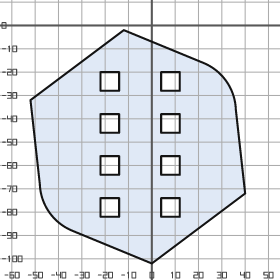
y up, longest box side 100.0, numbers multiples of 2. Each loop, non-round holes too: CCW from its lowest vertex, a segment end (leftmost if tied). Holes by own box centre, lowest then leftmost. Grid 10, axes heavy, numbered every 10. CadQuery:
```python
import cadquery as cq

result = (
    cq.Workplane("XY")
    .moveTo(0.0, -102.0)
    .lineTo(40.0, -72.0)
    .lineTo(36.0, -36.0)
    .threePointArc((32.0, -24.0), (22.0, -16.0))
    .lineTo(-12.0, -2.0)
    .lineTo(-52.0, -32.0)
    .lineTo(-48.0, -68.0)
    .threePointArc((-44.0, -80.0), (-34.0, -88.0))
    .close()
    .moveTo(-22.0, -82.0)
    .lineTo(-14.0, -82.0)
    .lineTo(-14.0, -74.0)
    .lineTo(-22.0, -74.0)
    .close()
    .moveTo(4.0, -82.0)
    .lineTo(12.0, -82.0)
    .lineTo(12.0, -74.0)
    .lineTo(4.0, -74.0)
    .close()
    .moveTo(-22.0, -64.0)
    .lineTo(-14.0, -64.0)
    .lineTo(-14.0, -56.0)
    .lineTo(-22.0, -56.0)
    .close()
    .moveTo(4.0, -64.0)
    .lineTo(12.0, -64.0)
    .lineTo(12.0, -56.0)
    .lineTo(4.0, -56.0)
    .close()
    .moveTo(-22.0, -46.0)
    .lineTo(-14.0, -46.0)
    .lineTo(-14.0, -38.0)
    .lineTo(-22.0, -38.0)
    .close()
    .moveTo(4.0, -46.0)
    .lineTo(12.0, -46.0)
    .lineTo(12.0, -38.0)
    .lineTo(4.0, -38.0)
    .close()
    .moveTo(-22.0, -28.0)
    .lineTo(-14.0, -28.0)
    .lineTo(-14.0, -20.0)
    .lineTo(-22.0, -20.0)
    .close()
    .moveTo(4.0, -28.0)
    .lineTo(12.0, -28.0)
    .lineTo(12.0, -20.0)
    .lineTo(4.0, -20.0)
    .close()
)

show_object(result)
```